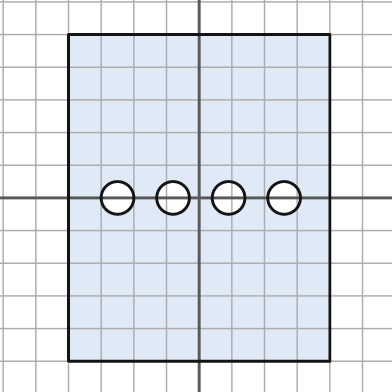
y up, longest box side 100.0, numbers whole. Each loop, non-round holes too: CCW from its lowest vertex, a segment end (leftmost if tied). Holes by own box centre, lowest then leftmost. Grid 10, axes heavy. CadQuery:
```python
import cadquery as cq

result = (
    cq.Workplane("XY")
    .moveTo(-40.0, -50.0)
    .lineTo(40.0, -50.0)
    .lineTo(40.0, 50.0)
    .lineTo(-40.0, 50.0)
    .close()
    .moveTo(-25.0, 0.0)
    .circle(5.0)
    .moveTo(-8.0, 0.0)
    .circle(5.0)
    .moveTo(9.0, 0.0)
    .circle(5.0)
    .moveTo(26.0, 0.0)
    .circle(5.0)
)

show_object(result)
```